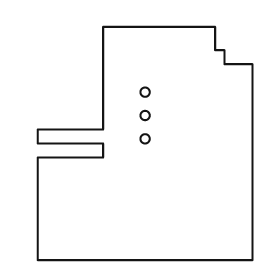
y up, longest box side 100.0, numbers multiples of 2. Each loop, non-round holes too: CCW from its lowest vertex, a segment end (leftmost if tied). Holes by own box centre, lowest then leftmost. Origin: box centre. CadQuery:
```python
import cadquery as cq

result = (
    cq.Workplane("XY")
    .moveTo(-46.0, -50.0)
    .lineTo(46.0, -50.0)
    .lineTo(46.0, 34.0)
    .lineTo(34.0, 34.0)
    .lineTo(34.0, 40.0)
    .lineTo(30.0, 40.0)
    .lineTo(30.0, 50.0)
    .lineTo(-18.0, 50.0)
    .lineTo(-18.0, 6.0)
    .lineTo(-46.0, 6.0)
    .lineTo(-46.0, 0.0)
    .lineTo(-18.0, 0.0)
    .lineTo(-18.0, -6.0)
    .lineTo(-46.0, -6.0)
    .close()
    .moveTo(0.0, 2.0)
    .circle(2.0)
    .moveTo(0.0, 12.0)
    .circle(2.0)
    .moveTo(0.0, 22.0)
    .circle(2.0)
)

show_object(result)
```